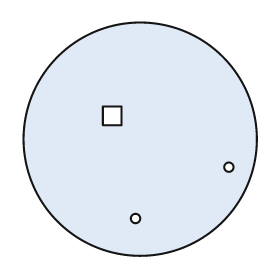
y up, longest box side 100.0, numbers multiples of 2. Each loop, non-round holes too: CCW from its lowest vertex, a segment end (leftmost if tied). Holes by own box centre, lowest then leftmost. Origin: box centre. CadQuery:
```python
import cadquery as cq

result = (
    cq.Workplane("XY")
    .moveTo(0.0, 0.0)
    .circle(50.0)
    .moveTo(-2.0, -34.0)
    .circle(2.0)
    .moveTo(38.0, -12.0)
    .circle(2.0)
    .moveTo(-16.0, 6.0)
    .lineTo(-8.0, 6.0)
    .lineTo(-8.0, 14.0)
    .lineTo(-16.0, 14.0)
    .close()
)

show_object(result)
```